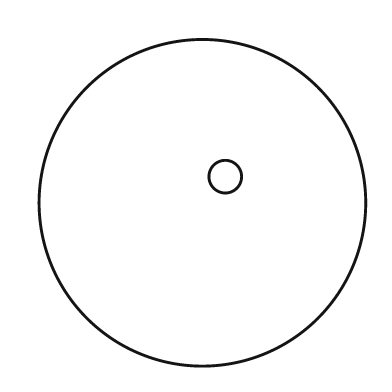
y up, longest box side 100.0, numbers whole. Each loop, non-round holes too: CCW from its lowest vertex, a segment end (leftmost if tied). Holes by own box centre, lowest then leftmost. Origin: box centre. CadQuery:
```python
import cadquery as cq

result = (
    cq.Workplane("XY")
    .moveTo(0.0, 0.0)
    .circle(50.0)
    .moveTo(7.0, 8.0)
    .circle(5.0)
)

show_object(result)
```